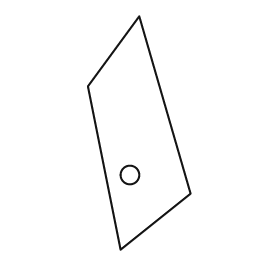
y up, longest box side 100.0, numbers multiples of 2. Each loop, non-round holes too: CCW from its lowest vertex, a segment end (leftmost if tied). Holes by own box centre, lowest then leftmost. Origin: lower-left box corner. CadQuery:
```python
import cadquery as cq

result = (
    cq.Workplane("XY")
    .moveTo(14.0, 0.0)
    .lineTo(44.0, 24.0)
    .lineTo(22.0, 100.0)
    .lineTo(0.0, 70.0)
    .close()
    .moveTo(18.0, 32.0)
    .circle(4.0)
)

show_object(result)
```